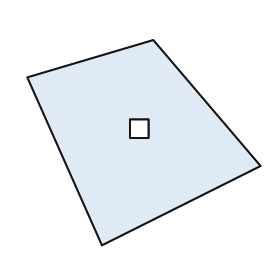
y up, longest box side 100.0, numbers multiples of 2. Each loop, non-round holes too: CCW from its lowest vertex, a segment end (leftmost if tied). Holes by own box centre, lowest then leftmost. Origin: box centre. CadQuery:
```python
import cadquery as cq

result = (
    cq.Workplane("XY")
    .moveTo(-18.0, -44.0)
    .lineTo(50.0, -10.0)
    .lineTo(4.0, 44.0)
    .lineTo(-50.0, 28.0)
    .close()
    .moveTo(-6.0, 2.0)
    .lineTo(2.0, 2.0)
    .lineTo(2.0, 10.0)
    .lineTo(-6.0, 10.0)
    .close()
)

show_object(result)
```